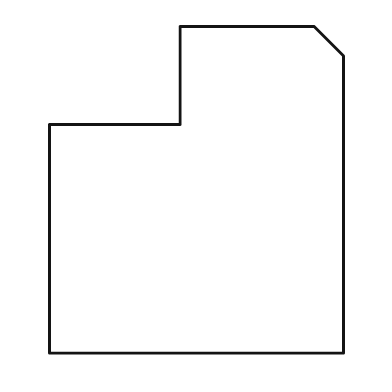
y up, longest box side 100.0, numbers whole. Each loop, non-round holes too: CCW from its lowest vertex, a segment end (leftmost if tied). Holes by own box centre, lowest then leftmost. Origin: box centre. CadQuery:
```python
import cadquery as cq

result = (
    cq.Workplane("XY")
    .moveTo(-45.0, -50.0)
    .lineTo(45.0, -50.0)
    .lineTo(45.0, 41.0)
    .lineTo(36.0, 50.0)
    .lineTo(-5.0, 50.0)
    .lineTo(-5.0, 20.0)
    .lineTo(-45.0, 20.0)
    .close()
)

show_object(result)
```